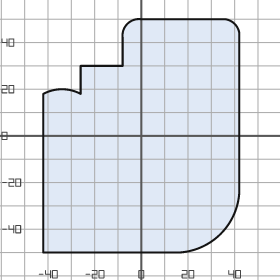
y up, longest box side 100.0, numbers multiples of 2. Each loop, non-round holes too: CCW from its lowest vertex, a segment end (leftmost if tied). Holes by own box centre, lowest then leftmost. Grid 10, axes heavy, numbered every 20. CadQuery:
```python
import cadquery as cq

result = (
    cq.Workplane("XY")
    .moveTo(-42.0, -50.0)
    .lineTo(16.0, -50.0)
    .threePointArc((34.0, -42.0), (42.0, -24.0))
    .lineTo(42.0, 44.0)
    .threePointArc((40.0, 48.0), (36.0, 50.0))
    .lineTo(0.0, 50.0)
    .threePointArc((-6.0, 48.0), (-8.0, 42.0))
    .lineTo(-8.0, 30.0)
    .lineTo(-26.0, 30.0)
    .lineTo(-26.0, 18.0)
    .threePointArc((-34.0, 20.0), (-42.0, 18.0))
    .close()
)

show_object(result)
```